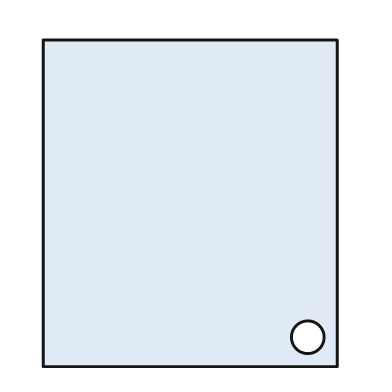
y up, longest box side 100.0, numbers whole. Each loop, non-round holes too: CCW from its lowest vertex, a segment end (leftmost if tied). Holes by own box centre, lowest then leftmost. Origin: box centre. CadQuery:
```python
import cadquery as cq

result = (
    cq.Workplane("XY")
    .moveTo(-45.0, -50.0)
    .lineTo(45.0, -50.0)
    .lineTo(45.0, 50.0)
    .lineTo(-45.0, 50.0)
    .close()
    .moveTo(36.0, -41.0)
    .circle(5.0)
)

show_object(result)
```